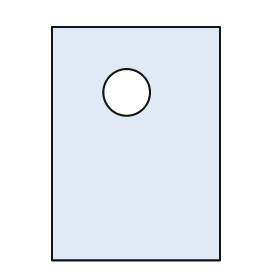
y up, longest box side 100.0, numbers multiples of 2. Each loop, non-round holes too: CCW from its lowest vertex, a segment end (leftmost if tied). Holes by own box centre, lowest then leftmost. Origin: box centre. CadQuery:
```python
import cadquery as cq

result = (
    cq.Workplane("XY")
    .moveTo(-36.0, -50.0)
    .lineTo(36.0, -50.0)
    .lineTo(36.0, 50.0)
    .lineTo(-36.0, 50.0)
    .close()
    .moveTo(-4.0, 22.0)
    .circle(10.0)
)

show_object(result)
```